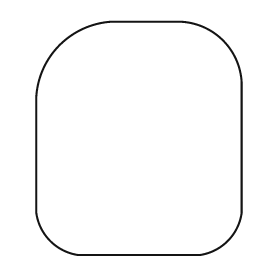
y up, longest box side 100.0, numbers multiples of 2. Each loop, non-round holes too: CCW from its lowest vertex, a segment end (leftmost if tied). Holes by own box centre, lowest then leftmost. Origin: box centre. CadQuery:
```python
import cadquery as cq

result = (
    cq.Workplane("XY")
    .moveTo(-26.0, -50.0)
    .lineTo(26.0, -50.0)
    .threePointArc((38.0, -44.0), (44.0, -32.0))
    .lineTo(44.0, 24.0)
    .threePointArc((36.0, 42.0), (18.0, 50.0))
    .lineTo(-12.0, 50.0)
    .threePointArc((-34.0, 40.0), (-44.0, 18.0))
    .lineTo(-44.0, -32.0)
    .threePointArc((-38.0, -44.0), (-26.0, -50.0))
    .close()
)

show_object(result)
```